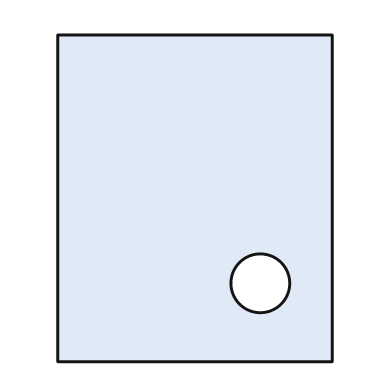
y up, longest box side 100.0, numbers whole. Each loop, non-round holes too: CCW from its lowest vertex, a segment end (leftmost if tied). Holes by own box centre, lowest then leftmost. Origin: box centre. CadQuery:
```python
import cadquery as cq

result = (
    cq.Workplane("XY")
    .moveTo(-42.0, -50.0)
    .lineTo(42.0, -50.0)
    .lineTo(42.0, 50.0)
    .lineTo(-42.0, 50.0)
    .close()
    .moveTo(20.0, -26.0)
    .circle(9.0)
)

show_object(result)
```